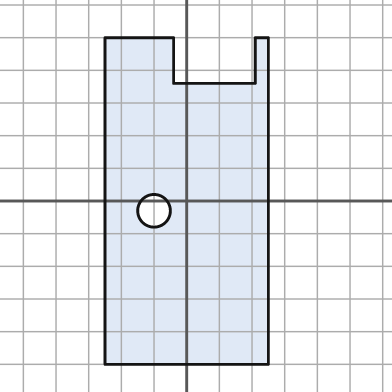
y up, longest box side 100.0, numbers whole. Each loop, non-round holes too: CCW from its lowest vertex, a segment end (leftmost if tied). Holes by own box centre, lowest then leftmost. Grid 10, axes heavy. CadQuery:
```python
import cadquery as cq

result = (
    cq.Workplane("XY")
    .moveTo(-25.0, -50.0)
    .lineTo(25.0, -50.0)
    .lineTo(25.0, 50.0)
    .lineTo(21.0, 50.0)
    .lineTo(21.0, 36.0)
    .lineTo(-4.0, 36.0)
    .lineTo(-4.0, 50.0)
    .lineTo(-25.0, 50.0)
    .close()
    .moveTo(-10.0, -3.0)
    .circle(5.0)
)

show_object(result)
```